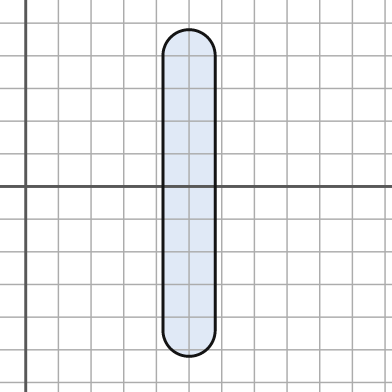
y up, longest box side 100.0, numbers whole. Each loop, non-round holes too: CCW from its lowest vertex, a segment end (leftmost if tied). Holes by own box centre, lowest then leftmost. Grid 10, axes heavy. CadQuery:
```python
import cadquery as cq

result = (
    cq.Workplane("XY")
    .moveTo(42.0, -44.0)
    .threePointArc((50.0, -52.0), (58.0, -44.0))
    .lineTo(58.0, 40.0)
    .threePointArc((50.0, 48.0), (42.0, 40.0))
    .close()
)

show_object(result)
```